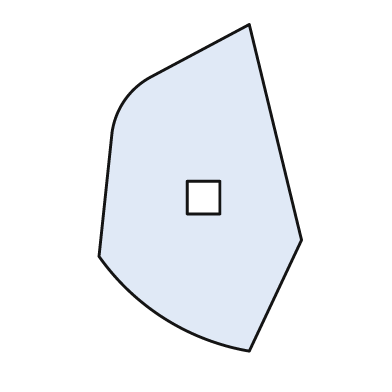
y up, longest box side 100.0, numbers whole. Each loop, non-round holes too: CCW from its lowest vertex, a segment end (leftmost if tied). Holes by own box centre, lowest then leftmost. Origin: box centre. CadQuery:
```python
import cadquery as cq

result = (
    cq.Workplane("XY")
    .moveTo(15.0, -50.0)
    .lineTo(31.0, -16.0)
    .lineTo(15.0, 50.0)
    .lineTo(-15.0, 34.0)
    .threePointArc((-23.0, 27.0), (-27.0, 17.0))
    .lineTo(-31.0, -21.0)
    .threePointArc((-11.0, -40.0), (15.0, -50.0))
    .close()
    .moveTo(-4.0, -8.0)
    .lineTo(6.0, -8.0)
    .lineTo(6.0, 2.0)
    .lineTo(-4.0, 2.0)
    .close()
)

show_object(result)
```